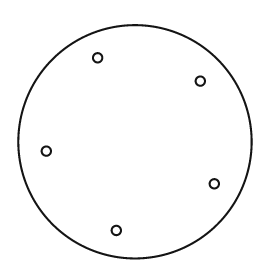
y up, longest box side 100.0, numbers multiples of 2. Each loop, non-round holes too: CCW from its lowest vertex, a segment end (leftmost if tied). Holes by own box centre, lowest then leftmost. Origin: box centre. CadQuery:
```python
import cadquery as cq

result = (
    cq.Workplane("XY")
    .moveTo(0.0, 0.0)
    .circle(50.0)
    .moveTo(-8.0, -38.0)
    .circle(2.0)
    .moveTo(34.0, -18.0)
    .circle(2.0)
    .moveTo(-38.0, -4.0)
    .circle(2.0)
    .moveTo(28.0, 26.0)
    .circle(2.0)
    .moveTo(-16.0, 36.0)
    .circle(2.0)
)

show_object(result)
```